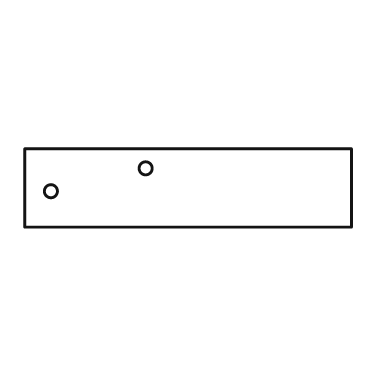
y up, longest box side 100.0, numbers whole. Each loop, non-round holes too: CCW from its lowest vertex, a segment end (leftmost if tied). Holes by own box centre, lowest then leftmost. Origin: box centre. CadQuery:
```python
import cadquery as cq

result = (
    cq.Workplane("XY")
    .moveTo(-50.0, -12.0)
    .lineTo(50.0, -12.0)
    .lineTo(50.0, 12.0)
    .lineTo(-50.0, 12.0)
    .close()
    .moveTo(-42.0, -1.0)
    .circle(2.0)
    .moveTo(-13.0, 6.0)
    .circle(2.0)
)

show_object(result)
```